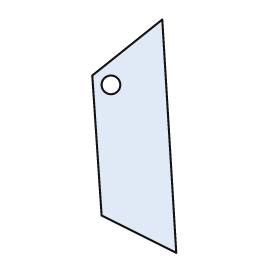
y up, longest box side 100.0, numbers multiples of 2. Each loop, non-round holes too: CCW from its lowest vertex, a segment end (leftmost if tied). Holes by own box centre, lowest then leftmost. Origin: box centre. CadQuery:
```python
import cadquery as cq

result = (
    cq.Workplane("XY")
    .moveTo(18.0, -50.0)
    .lineTo(12.0, 50.0)
    .lineTo(-18.0, 26.0)
    .lineTo(-14.0, -34.0)
    .close()
    .moveTo(-10.0, 22.0)
    .circle(4.0)
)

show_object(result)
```